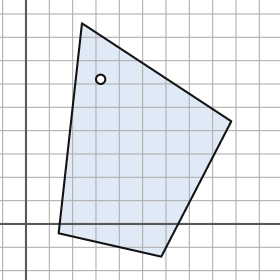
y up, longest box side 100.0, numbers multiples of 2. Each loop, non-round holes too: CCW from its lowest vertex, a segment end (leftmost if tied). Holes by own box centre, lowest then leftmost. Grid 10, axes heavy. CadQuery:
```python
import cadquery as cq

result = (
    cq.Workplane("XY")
    .moveTo(58.0, -14.0)
    .lineTo(88.0, 44.0)
    .lineTo(24.0, 86.0)
    .lineTo(14.0, -4.0)
    .close()
    .moveTo(32.0, 62.0)
    .circle(2.0)
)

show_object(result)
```